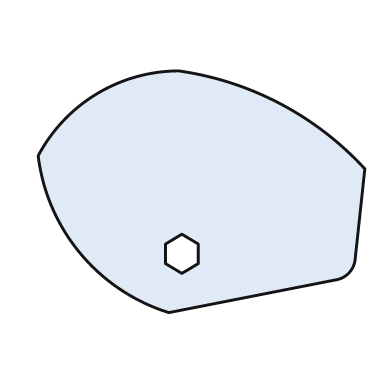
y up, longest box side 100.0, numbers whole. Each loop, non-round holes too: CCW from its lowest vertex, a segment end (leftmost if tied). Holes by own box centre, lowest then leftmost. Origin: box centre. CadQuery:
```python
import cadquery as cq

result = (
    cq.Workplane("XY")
    .moveTo(-10.0, -37.0)
    .lineTo(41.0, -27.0)
    .threePointArc((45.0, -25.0), (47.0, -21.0))
    .lineTo(50.0, 7.0)
    .threePointArc((24.0, 27.0), (-7.0, 37.0))
    .threePointArc((-32.0, 30.0), (-50.0, 11.0))
    .threePointArc((-37.0, -19.0), (-10.0, -37.0))
    .close()
    .moveTo(-6.0, -25.0)
    .lineTo(-1.0, -22.0)
    .lineTo(-1.0, -16.0)
    .lineTo(-6.0, -13.0)
    .lineTo(-11.0, -16.0)
    .lineTo(-11.0, -22.0)
    .close()
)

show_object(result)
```